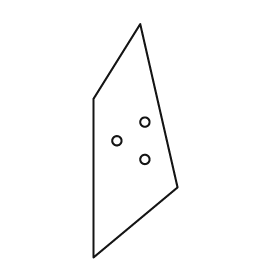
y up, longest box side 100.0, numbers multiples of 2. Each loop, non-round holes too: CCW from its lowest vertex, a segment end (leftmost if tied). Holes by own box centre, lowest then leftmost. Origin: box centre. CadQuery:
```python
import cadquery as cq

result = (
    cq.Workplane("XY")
    .moveTo(-18.0, -50.0)
    .lineTo(18.0, -20.0)
    .lineTo(2.0, 50.0)
    .lineTo(-18.0, 18.0)
    .close()
    .moveTo(4.0, -8.0)
    .circle(2.0)
    .moveTo(-8.0, 0.0)
    .circle(2.0)
    .moveTo(4.0, 8.0)
    .circle(2.0)
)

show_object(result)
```